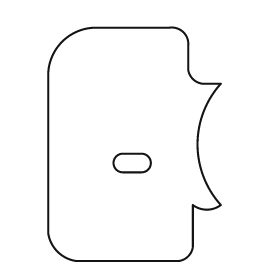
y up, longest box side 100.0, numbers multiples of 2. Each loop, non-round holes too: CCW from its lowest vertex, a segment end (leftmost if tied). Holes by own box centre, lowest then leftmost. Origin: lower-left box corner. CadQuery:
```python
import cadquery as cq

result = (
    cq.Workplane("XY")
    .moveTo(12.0, 0.0)
    .lineTo(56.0, 0.0)
    .threePointArc((60.0, 2.0), (62.0, 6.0))
    .lineTo(62.0, 24.0)
    .threePointArc((68.0, 22.0), (74.0, 24.0))
    .threePointArc((64.0, 50.0), (74.0, 76.0))
    .lineTo(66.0, 76.0)
    .threePointArc((62.0, 78.0), (60.0, 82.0))
    .lineTo(60.0, 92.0)
    .threePointArc((58.0, 98.0), (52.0, 100.0))
    .lineTo(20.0, 100.0)
    .threePointArc((6.0, 94.0), (0.0, 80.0))
    .lineTo(0.0, 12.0)
    .threePointArc((4.0, 4.0), (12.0, 0.0))
    .close()
    .moveTo(32.0, 38.0)
    .lineTo(40.0, 38.0)
    .threePointArc((44.0, 42.0), (40.0, 46.0))
    .lineTo(32.0, 46.0)
    .threePointArc((28.0, 42.0), (32.0, 38.0))
    .close()
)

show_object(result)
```